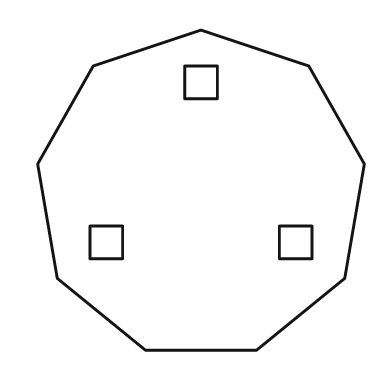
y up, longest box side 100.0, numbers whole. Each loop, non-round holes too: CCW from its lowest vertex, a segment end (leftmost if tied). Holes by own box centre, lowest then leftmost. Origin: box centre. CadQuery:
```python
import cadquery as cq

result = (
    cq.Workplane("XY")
    .moveTo(-17.0, -49.0)
    .lineTo(17.0, -49.0)
    .lineTo(44.0, -27.0)
    .lineTo(50.0, 8.0)
    .lineTo(33.0, 38.0)
    .lineTo(0.0, 49.0)
    .lineTo(-33.0, 38.0)
    .lineTo(-50.0, 8.0)
    .lineTo(-44.0, -27.0)
    .close()
    .moveTo(-34.0, -21.0)
    .lineTo(-24.0, -21.0)
    .lineTo(-24.0, -11.0)
    .lineTo(-34.0, -11.0)
    .close()
    .moveTo(24.0, -21.0)
    .lineTo(34.0, -21.0)
    .lineTo(34.0, -11.0)
    .lineTo(24.0, -11.0)
    .close()
    .moveTo(-5.0, 28.0)
    .lineTo(5.0, 28.0)
    .lineTo(5.0, 38.0)
    .lineTo(-5.0, 38.0)
    .close()
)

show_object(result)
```